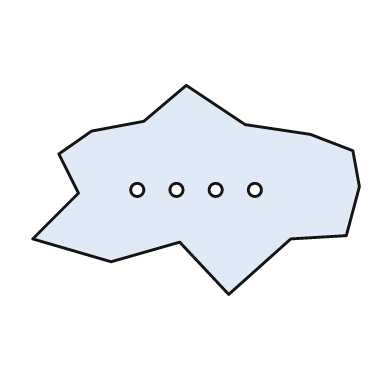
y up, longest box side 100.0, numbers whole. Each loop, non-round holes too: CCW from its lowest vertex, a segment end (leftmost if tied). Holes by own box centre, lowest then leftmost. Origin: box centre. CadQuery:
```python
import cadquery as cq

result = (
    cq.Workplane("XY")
    .moveTo(10.0, -32.0)
    .lineTo(29.0, -15.0)
    .lineTo(46.0, -14.0)
    .lineTo(50.0, 1.0)
    .lineTo(48.0, 12.0)
    .lineTo(35.0, 17.0)
    .lineTo(15.0, 20.0)
    .lineTo(-3.0, 32.0)
    .lineTo(-16.0, 21.0)
    .lineTo(-32.0, 18.0)
    .lineTo(-42.0, 11.0)
    .lineTo(-36.0, -1.0)
    .lineTo(-50.0, -15.0)
    .lineTo(-26.0, -22.0)
    .lineTo(-5.0, -16.0)
    .close()
    .moveTo(-18.0, 0.0)
    .circle(2.0)
    .moveTo(-6.0, 0.0)
    .circle(2.0)
    .moveTo(6.0, 0.0)
    .circle(2.0)
    .moveTo(18.0, 0.0)
    .circle(2.0)
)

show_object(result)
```